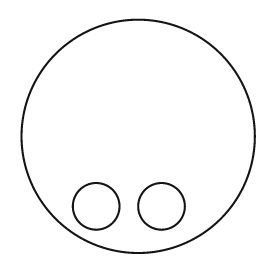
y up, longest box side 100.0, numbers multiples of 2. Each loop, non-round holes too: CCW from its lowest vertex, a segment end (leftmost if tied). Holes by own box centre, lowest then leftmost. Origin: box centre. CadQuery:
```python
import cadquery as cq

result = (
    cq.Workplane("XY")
    .moveTo(0.0, 0.0)
    .circle(50.0)
    .moveTo(-18.0, -30.0)
    .circle(10.0)
    .moveTo(10.0, -30.0)
    .circle(10.0)
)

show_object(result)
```